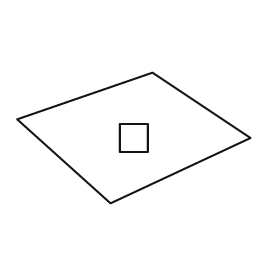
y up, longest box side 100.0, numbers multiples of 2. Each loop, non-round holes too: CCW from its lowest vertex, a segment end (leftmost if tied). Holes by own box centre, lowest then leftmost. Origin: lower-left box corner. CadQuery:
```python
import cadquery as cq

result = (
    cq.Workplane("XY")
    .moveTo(40.0, 0.0)
    .lineTo(100.0, 28.0)
    .lineTo(58.0, 56.0)
    .lineTo(0.0, 36.0)
    .close()
    .moveTo(44.0, 22.0)
    .lineTo(56.0, 22.0)
    .lineTo(56.0, 34.0)
    .lineTo(44.0, 34.0)
    .close()
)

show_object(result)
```